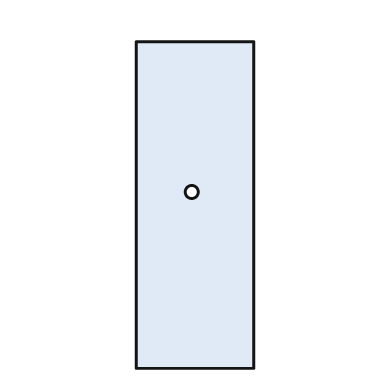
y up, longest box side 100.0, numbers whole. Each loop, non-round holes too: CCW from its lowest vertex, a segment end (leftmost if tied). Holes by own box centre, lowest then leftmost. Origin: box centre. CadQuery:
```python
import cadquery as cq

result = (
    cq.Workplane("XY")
    .moveTo(-18.0, -50.0)
    .lineTo(18.0, -50.0)
    .lineTo(18.0, 50.0)
    .lineTo(-18.0, 50.0)
    .close()
    .moveTo(-1.0, 4.0)
    .circle(2.0)
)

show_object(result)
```